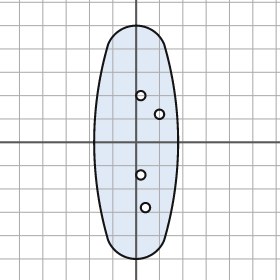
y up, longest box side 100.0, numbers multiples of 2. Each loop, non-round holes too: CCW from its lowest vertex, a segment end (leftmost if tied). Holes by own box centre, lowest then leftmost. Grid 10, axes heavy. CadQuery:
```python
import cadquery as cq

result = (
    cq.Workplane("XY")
    .moveTo(-12.0, -42.0)
    .threePointArc((0.0, -50.0), (12.0, -42.0))
    .threePointArc((18.0, 0.0), (12.0, 42.0))
    .threePointArc((0.0, 50.0), (-12.0, 42.0))
    .threePointArc((-18.0, 0.0), (-12.0, -42.0))
    .close()
    .moveTo(4.0, -28.0)
    .circle(2.0)
    .moveTo(2.0, -14.0)
    .circle(2.0)
    .moveTo(10.0, 12.0)
    .circle(2.0)
    .moveTo(2.0, 20.0)
    .circle(2.0)
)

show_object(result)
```